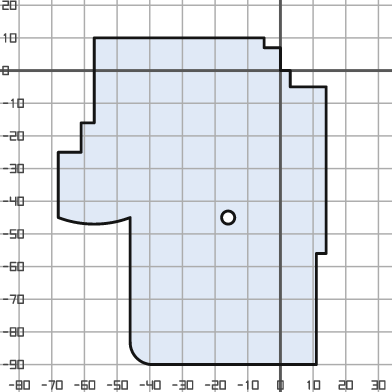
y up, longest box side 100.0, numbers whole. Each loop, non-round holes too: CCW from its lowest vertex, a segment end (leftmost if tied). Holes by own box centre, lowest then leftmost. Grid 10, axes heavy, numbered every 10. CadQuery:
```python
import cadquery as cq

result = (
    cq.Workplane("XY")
    .moveTo(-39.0, -90.0)
    .lineTo(11.0, -90.0)
    .lineTo(11.0, -56.0)
    .lineTo(14.0, -56.0)
    .lineTo(14.0, -5.0)
    .lineTo(3.0, -5.0)
    .lineTo(3.0, 0.0)
    .lineTo(0.0, 0.0)
    .lineTo(0.0, 7.0)
    .lineTo(-5.0, 7.0)
    .lineTo(-5.0, 10.0)
    .lineTo(-57.0, 10.0)
    .lineTo(-57.0, -16.0)
    .lineTo(-61.0, -16.0)
    .lineTo(-61.0, -25.0)
    .lineTo(-68.0, -25.0)
    .lineTo(-68.0, -45.0)
    .threePointArc((-57.0, -47.0), (-46.0, -45.0))
    .lineTo(-46.0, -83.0)
    .threePointArc((-44.0, -88.0), (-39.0, -90.0))
    .close()
    .moveTo(-16.0, -45.0)
    .circle(2.0)
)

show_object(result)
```